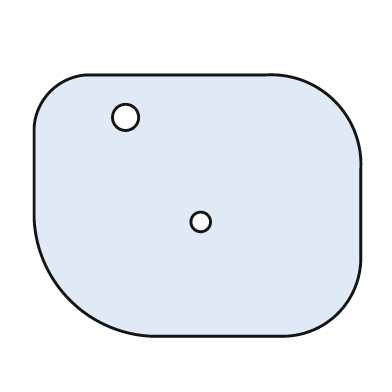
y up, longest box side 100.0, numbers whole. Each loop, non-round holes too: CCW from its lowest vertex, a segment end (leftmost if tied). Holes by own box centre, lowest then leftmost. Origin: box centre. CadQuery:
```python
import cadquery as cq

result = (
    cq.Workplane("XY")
    .moveTo(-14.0, -40.0)
    .lineTo(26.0, -40.0)
    .threePointArc((43.0, -33.0), (50.0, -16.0))
    .lineTo(50.0, 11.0)
    .threePointArc((42.0, 32.0), (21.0, 40.0))
    .lineTo(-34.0, 40.0)
    .threePointArc((-45.0, 35.0), (-50.0, 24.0))
    .lineTo(-50.0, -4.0)
    .threePointArc((-39.0, -29.0), (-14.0, -40.0))
    .close()
    .moveTo(1.0, -5.0)
    .circle(3.0)
    .moveTo(-22.0, 27.0)
    .circle(4.0)
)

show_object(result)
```